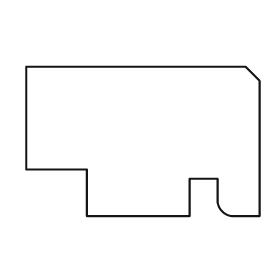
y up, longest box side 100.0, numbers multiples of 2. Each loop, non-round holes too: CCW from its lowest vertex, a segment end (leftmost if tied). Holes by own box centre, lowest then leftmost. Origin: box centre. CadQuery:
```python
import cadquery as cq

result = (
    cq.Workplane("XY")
    .moveTo(-24.0, -32.0)
    .lineTo(20.0, -32.0)
    .lineTo(20.0, -16.0)
    .lineTo(32.0, -16.0)
    .lineTo(32.0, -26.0)
    .threePointArc((34.0, -30.0), (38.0, -32.0))
    .lineTo(50.0, -32.0)
    .lineTo(50.0, 26.0)
    .lineTo(44.0, 32.0)
    .lineTo(-50.0, 32.0)
    .lineTo(-50.0, -12.0)
    .lineTo(-24.0, -12.0)
    .close()
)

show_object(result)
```